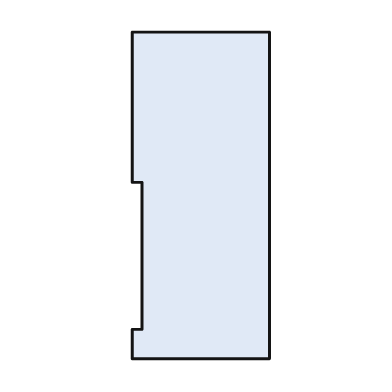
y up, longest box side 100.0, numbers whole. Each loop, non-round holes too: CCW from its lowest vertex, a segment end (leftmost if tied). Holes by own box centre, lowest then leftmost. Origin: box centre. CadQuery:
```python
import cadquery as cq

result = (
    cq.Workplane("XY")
    .moveTo(-21.0, -50.0)
    .lineTo(21.0, -50.0)
    .lineTo(21.0, 50.0)
    .lineTo(-21.0, 50.0)
    .lineTo(-21.0, 4.0)
    .lineTo(-18.0, 4.0)
    .lineTo(-18.0, -41.0)
    .lineTo(-21.0, -41.0)
    .close()
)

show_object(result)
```